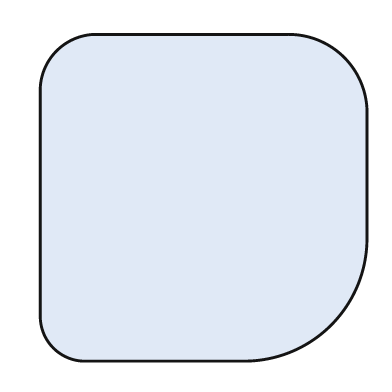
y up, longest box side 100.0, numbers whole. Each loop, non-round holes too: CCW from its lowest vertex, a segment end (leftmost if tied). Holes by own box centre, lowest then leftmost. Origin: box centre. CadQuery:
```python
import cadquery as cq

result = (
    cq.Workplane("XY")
    .moveTo(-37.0, -50.0)
    .lineTo(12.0, -50.0)
    .threePointArc((39.0, -39.0), (50.0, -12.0))
    .lineTo(50.0, 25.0)
    .threePointArc((43.0, 43.0), (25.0, 50.0))
    .lineTo(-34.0, 50.0)
    .threePointArc((-45.0, 45.0), (-50.0, 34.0))
    .lineTo(-50.0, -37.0)
    .threePointArc((-46.0, -46.0), (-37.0, -50.0))
    .close()
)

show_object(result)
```